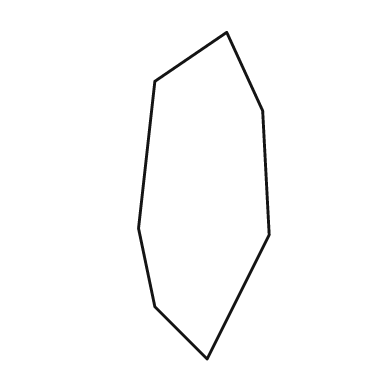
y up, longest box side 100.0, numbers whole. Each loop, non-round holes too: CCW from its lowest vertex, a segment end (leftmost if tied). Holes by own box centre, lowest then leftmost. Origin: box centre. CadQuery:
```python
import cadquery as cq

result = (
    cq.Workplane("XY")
    .moveTo(1.0, -50.0)
    .lineTo(20.0, -12.0)
    .lineTo(18.0, 26.0)
    .lineTo(7.0, 50.0)
    .lineTo(-15.0, 35.0)
    .lineTo(-20.0, -10.0)
    .lineTo(-15.0, -34.0)
    .close()
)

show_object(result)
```